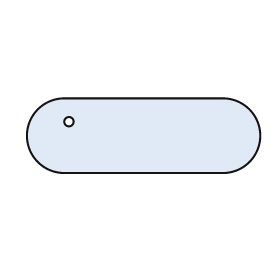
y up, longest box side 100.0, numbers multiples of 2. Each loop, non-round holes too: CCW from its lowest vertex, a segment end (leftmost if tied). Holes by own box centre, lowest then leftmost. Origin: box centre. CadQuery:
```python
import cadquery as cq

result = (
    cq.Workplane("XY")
    .moveTo(-34.0, -16.0)
    .lineTo(34.0, -16.0)
    .threePointArc((50.0, 0.0), (34.0, 16.0))
    .lineTo(-34.0, 16.0)
    .threePointArc((-50.0, 0.0), (-34.0, -16.0))
    .close()
    .moveTo(-32.0, 6.0)
    .circle(2.0)
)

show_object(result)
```